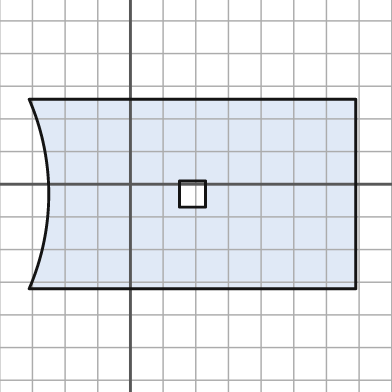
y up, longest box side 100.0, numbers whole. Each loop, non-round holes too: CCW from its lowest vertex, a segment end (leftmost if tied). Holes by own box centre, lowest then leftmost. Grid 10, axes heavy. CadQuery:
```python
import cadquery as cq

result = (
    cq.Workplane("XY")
    .moveTo(-31.0, -32.0)
    .lineTo(69.0, -32.0)
    .lineTo(69.0, 26.0)
    .lineTo(-31.0, 26.0)
    .threePointArc((-25.0, -3.0), (-31.0, -32.0))
    .close()
    .moveTo(15.0, -7.0)
    .lineTo(23.0, -7.0)
    .lineTo(23.0, 1.0)
    .lineTo(15.0, 1.0)
    .close()
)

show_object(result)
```